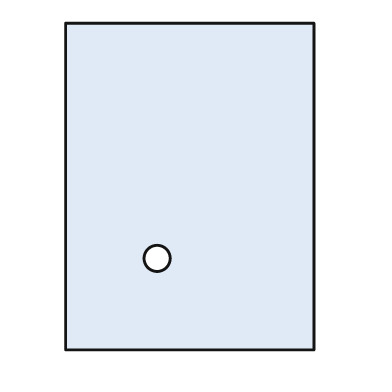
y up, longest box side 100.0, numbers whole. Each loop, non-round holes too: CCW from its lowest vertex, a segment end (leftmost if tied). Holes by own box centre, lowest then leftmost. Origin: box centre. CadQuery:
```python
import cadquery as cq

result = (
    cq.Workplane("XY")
    .moveTo(-38.0, -50.0)
    .lineTo(38.0, -50.0)
    .lineTo(38.0, 50.0)
    .lineTo(-38.0, 50.0)
    .close()
    .moveTo(-10.0, -22.0)
    .circle(4.0)
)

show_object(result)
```